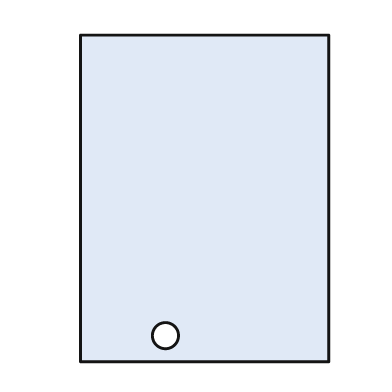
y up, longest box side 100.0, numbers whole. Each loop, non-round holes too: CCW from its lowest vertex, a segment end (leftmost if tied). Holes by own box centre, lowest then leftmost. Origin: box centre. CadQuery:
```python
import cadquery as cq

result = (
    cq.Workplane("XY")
    .moveTo(-38.0, -50.0)
    .lineTo(38.0, -50.0)
    .lineTo(38.0, 50.0)
    .lineTo(-38.0, 50.0)
    .close()
    .moveTo(-12.0, -42.0)
    .circle(4.0)
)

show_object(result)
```